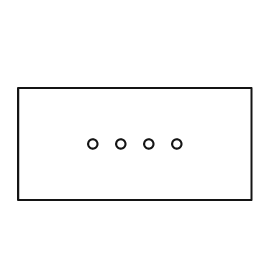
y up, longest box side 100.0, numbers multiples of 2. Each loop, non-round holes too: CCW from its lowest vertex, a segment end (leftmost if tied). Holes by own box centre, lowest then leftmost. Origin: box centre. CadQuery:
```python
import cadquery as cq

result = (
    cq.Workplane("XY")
    .moveTo(-50.0, -24.0)
    .lineTo(50.0, -24.0)
    .lineTo(50.0, 24.0)
    .lineTo(-50.0, 24.0)
    .close()
    .moveTo(-18.0, 0.0)
    .circle(2.0)
    .moveTo(-6.0, 0.0)
    .circle(2.0)
    .moveTo(6.0, 0.0)
    .circle(2.0)
    .moveTo(18.0, 0.0)
    .circle(2.0)
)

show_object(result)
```